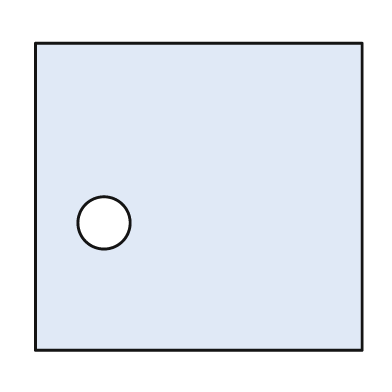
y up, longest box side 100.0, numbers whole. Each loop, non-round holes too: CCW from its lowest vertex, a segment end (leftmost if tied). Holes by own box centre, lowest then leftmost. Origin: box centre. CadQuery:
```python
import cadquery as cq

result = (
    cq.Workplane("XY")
    .moveTo(-50.0, -47.0)
    .lineTo(50.0, -47.0)
    .lineTo(50.0, 47.0)
    .lineTo(-50.0, 47.0)
    .close()
    .moveTo(-29.0, -8.0)
    .circle(8.0)
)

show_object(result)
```